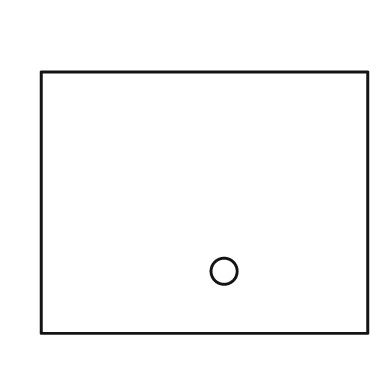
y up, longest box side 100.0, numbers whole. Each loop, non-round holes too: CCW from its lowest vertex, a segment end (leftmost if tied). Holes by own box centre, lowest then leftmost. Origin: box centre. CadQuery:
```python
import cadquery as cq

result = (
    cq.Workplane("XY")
    .moveTo(-50.0, -40.0)
    .lineTo(50.0, -40.0)
    .lineTo(50.0, 40.0)
    .lineTo(-50.0, 40.0)
    .close()
    .moveTo(6.0, -21.0)
    .circle(4.0)
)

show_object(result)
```